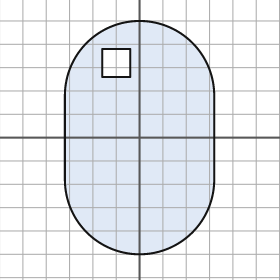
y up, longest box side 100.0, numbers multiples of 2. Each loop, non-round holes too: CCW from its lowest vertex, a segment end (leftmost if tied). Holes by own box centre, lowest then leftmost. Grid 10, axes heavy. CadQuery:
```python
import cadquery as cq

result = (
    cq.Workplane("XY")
    .moveTo(-32.0, -18.0)
    .threePointArc((0.0, -50.0), (32.0, -18.0))
    .lineTo(32.0, 18.0)
    .threePointArc((0.0, 50.0), (-32.0, 18.0))
    .close()
    .moveTo(-16.0, 26.0)
    .lineTo(-4.0, 26.0)
    .lineTo(-4.0, 38.0)
    .lineTo(-16.0, 38.0)
    .close()
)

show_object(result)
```